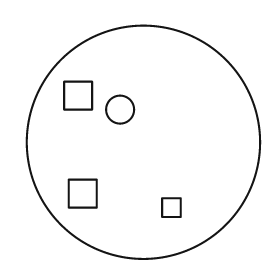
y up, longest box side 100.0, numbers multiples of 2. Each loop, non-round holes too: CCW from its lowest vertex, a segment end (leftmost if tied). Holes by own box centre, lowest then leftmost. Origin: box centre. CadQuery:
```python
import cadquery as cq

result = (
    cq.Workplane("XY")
    .moveTo(0.0, 0.0)
    .circle(50.0)
    .moveTo(8.0, -32.0)
    .lineTo(16.0, -32.0)
    .lineTo(16.0, -24.0)
    .lineTo(8.0, -24.0)
    .close()
    .moveTo(-32.0, -28.0)
    .lineTo(-20.0, -28.0)
    .lineTo(-20.0, -16.0)
    .lineTo(-32.0, -16.0)
    .close()
    .moveTo(-10.0, 14.0)
    .circle(6.0)
    .moveTo(-34.0, 14.0)
    .lineTo(-22.0, 14.0)
    .lineTo(-22.0, 26.0)
    .lineTo(-34.0, 26.0)
    .close()
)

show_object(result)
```